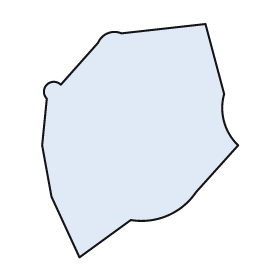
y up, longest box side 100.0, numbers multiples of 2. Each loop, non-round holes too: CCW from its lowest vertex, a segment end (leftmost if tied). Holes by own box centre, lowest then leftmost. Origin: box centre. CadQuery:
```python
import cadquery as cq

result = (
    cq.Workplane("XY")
    .moveTo(-26.0, -50.0)
    .lineTo(-4.0, -34.0)
    .threePointArc((12.0, -32.0), (24.0, -22.0))
    .lineTo(42.0, -2.0)
    .threePointArc((36.0, 8.0), (36.0, 20.0))
    .lineTo(28.0, 50.0)
    .lineTo(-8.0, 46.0)
    .threePointArc((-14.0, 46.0), (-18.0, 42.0))
    .lineTo(-34.0, 24.0)
    .threePointArc((-40.0, 24.0), (-40.0, 18.0))
    .lineTo(-42.0, -2.0)
    .lineTo(-38.0, -24.0)
    .close()
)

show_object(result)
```